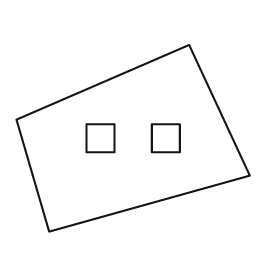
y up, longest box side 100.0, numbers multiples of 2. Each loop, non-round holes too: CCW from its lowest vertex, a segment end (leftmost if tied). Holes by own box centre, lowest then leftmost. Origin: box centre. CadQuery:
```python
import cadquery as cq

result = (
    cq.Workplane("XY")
    .moveTo(-36.0, -40.0)
    .lineTo(50.0, -16.0)
    .lineTo(24.0, 40.0)
    .lineTo(-50.0, 8.0)
    .close()
    .moveTo(-20.0, -6.0)
    .lineTo(-8.0, -6.0)
    .lineTo(-8.0, 6.0)
    .lineTo(-20.0, 6.0)
    .close()
    .moveTo(8.0, -6.0)
    .lineTo(20.0, -6.0)
    .lineTo(20.0, 6.0)
    .lineTo(8.0, 6.0)
    .close()
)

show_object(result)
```